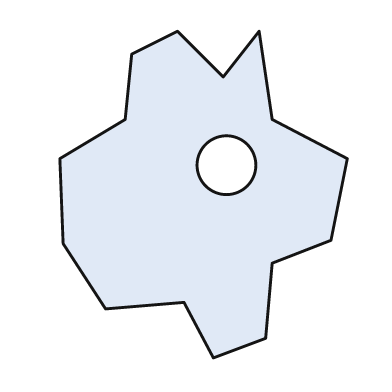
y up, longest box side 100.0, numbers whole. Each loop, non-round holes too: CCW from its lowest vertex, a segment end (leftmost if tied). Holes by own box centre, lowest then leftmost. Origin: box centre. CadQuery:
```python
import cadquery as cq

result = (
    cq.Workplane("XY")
    .moveTo(3.0, -50.0)
    .lineTo(19.0, -44.0)
    .lineTo(21.0, -21.0)
    .lineTo(39.0, -14.0)
    .lineTo(44.0, 11.0)
    .lineTo(21.0, 23.0)
    .lineTo(17.0, 50.0)
    .lineTo(6.0, 36.0)
    .lineTo(-8.0, 50.0)
    .lineTo(-22.0, 43.0)
    .lineTo(-24.0, 23.0)
    .lineTo(-44.0, 11.0)
    .lineTo(-43.0, -15.0)
    .lineTo(-30.0, -35.0)
    .lineTo(-6.0, -33.0)
    .close()
    .moveTo(7.0, 9.0)
    .circle(9.0)
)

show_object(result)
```